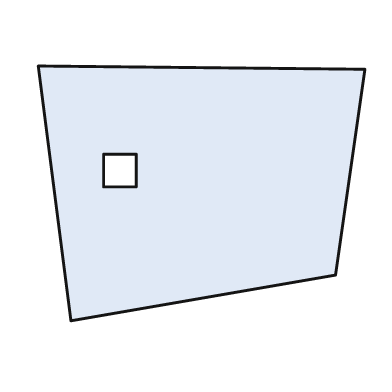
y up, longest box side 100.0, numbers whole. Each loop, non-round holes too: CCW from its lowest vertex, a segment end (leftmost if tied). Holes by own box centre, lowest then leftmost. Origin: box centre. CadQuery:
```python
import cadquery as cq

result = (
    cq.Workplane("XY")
    .moveTo(-40.0, -39.0)
    .lineTo(41.0, -25.0)
    .lineTo(50.0, 38.0)
    .lineTo(-50.0, 39.0)
    .close()
    .moveTo(-30.0, 2.0)
    .lineTo(-20.0, 2.0)
    .lineTo(-20.0, 12.0)
    .lineTo(-30.0, 12.0)
    .close()
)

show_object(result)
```